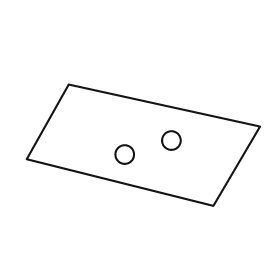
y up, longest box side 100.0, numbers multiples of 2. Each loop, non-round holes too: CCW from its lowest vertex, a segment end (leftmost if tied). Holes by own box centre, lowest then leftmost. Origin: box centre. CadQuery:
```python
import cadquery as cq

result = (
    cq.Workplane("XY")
    .moveTo(30.0, -26.0)
    .lineTo(50.0, 8.0)
    .lineTo(-32.0, 26.0)
    .lineTo(-50.0, -6.0)
    .close()
    .moveTo(-8.0, -4.0)
    .circle(4.0)
    .moveTo(12.0, 2.0)
    .circle(4.0)
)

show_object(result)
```